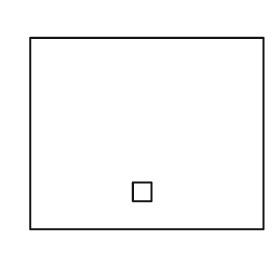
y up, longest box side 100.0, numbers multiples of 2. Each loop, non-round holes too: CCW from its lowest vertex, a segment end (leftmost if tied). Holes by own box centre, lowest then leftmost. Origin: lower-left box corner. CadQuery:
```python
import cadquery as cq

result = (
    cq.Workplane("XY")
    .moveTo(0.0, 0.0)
    .lineTo(100.0, 0.0)
    .lineTo(100.0, 82.0)
    .lineTo(0.0, 82.0)
    .close()
    .moveTo(44.0, 12.0)
    .lineTo(52.0, 12.0)
    .lineTo(52.0, 20.0)
    .lineTo(44.0, 20.0)
    .close()
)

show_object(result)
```